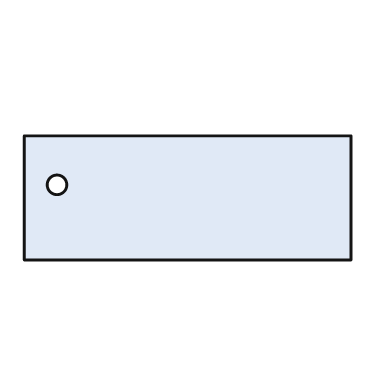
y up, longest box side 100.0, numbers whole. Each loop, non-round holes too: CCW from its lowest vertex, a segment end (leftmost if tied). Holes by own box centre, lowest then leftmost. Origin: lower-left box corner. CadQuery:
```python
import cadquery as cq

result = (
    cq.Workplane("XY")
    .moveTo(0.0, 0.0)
    .lineTo(100.0, 0.0)
    .lineTo(100.0, 38.0)
    .lineTo(0.0, 38.0)
    .close()
    .moveTo(10.0, 23.0)
    .circle(3.0)
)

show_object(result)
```